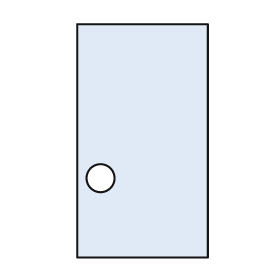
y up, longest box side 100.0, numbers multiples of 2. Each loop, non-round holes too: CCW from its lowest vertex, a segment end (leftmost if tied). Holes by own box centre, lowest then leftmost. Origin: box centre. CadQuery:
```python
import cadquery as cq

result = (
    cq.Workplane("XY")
    .moveTo(-28.0, -50.0)
    .lineTo(28.0, -50.0)
    .lineTo(28.0, 50.0)
    .lineTo(-28.0, 50.0)
    .close()
    .moveTo(-18.0, -16.0)
    .circle(6.0)
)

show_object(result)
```